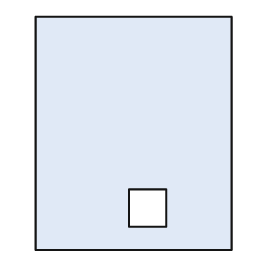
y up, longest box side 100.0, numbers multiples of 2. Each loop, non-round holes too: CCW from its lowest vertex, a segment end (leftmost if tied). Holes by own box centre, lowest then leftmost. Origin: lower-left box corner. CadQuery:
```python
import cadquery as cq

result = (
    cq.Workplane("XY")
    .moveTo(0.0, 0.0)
    .lineTo(84.0, 0.0)
    .lineTo(84.0, 100.0)
    .lineTo(0.0, 100.0)
    .close()
    .moveTo(40.0, 10.0)
    .lineTo(56.0, 10.0)
    .lineTo(56.0, 26.0)
    .lineTo(40.0, 26.0)
    .close()
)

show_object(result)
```